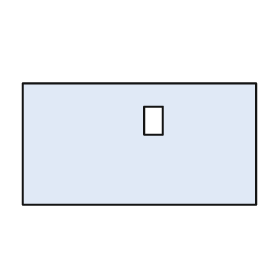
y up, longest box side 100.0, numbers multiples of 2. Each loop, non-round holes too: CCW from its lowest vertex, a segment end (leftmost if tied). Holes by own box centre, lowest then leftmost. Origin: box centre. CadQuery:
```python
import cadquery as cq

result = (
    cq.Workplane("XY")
    .moveTo(-50.0, -26.0)
    .lineTo(50.0, -26.0)
    .lineTo(50.0, 26.0)
    .lineTo(-50.0, 26.0)
    .close()
    .moveTo(2.0, 4.0)
    .lineTo(10.0, 4.0)
    .lineTo(10.0, 16.0)
    .lineTo(2.0, 16.0)
    .close()
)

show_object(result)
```